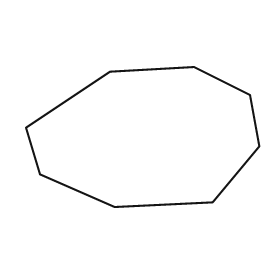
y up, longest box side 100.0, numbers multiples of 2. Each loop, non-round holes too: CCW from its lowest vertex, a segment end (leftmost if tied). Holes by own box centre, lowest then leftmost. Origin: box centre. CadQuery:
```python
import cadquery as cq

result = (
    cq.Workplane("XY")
    .moveTo(-12.0, -30.0)
    .lineTo(30.0, -28.0)
    .lineTo(50.0, -4.0)
    .lineTo(46.0, 18.0)
    .lineTo(22.0, 30.0)
    .lineTo(-14.0, 28.0)
    .lineTo(-50.0, 4.0)
    .lineTo(-44.0, -16.0)
    .close()
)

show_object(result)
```